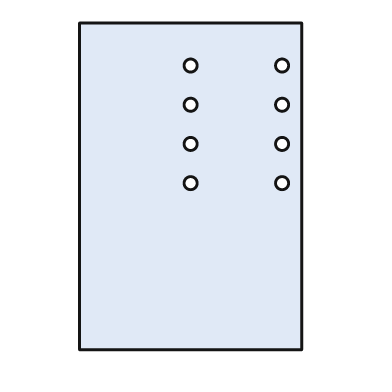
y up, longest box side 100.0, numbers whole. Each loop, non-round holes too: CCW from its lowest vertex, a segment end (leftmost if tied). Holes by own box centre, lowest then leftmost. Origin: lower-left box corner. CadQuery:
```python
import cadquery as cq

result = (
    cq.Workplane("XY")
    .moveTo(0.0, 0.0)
    .lineTo(68.0, 0.0)
    .lineTo(68.0, 100.0)
    .lineTo(0.0, 100.0)
    .close()
    .moveTo(34.0, 51.0)
    .circle(2.0)
    .moveTo(62.0, 51.0)
    .circle(2.0)
    .moveTo(34.0, 63.0)
    .circle(2.0)
    .moveTo(62.0, 63.0)
    .circle(2.0)
    .moveTo(34.0, 75.0)
    .circle(2.0)
    .moveTo(62.0, 75.0)
    .circle(2.0)
    .moveTo(34.0, 87.0)
    .circle(2.0)
    .moveTo(62.0, 87.0)
    .circle(2.0)
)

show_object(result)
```